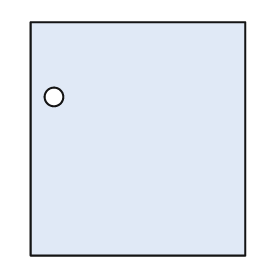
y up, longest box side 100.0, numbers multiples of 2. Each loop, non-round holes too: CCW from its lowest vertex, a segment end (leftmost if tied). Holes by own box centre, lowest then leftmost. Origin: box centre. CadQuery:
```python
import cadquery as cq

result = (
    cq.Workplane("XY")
    .moveTo(-46.0, -50.0)
    .lineTo(46.0, -50.0)
    .lineTo(46.0, 50.0)
    .lineTo(-46.0, 50.0)
    .close()
    .moveTo(-36.0, 18.0)
    .circle(4.0)
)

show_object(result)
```